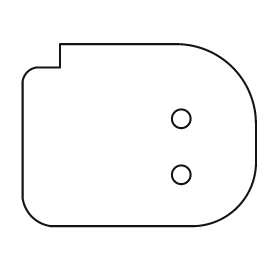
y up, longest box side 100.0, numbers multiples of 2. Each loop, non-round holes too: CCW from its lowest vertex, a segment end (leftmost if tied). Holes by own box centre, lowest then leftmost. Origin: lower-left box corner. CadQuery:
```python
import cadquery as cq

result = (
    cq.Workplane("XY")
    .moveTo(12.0, 0.0)
    .lineTo(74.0, 0.0)
    .threePointArc((92.0, 8.0), (100.0, 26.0))
    .lineTo(100.0, 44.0)
    .threePointArc((90.0, 68.0), (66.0, 78.0))
    .lineTo(16.0, 78.0)
    .lineTo(16.0, 68.0)
    .lineTo(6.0, 68.0)
    .threePointArc((2.0, 66.0), (0.0, 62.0))
    .lineTo(0.0, 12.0)
    .threePointArc((4.0, 4.0), (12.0, 0.0))
    .close()
    .moveTo(68.0, 22.0)
    .circle(4.0)
    .moveTo(68.0, 46.0)
    .circle(4.0)
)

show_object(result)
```